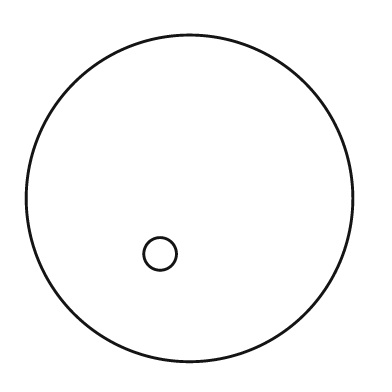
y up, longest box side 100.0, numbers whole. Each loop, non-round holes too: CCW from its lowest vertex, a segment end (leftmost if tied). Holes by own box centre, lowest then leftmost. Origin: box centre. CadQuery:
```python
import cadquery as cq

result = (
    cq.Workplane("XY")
    .moveTo(0.0, 0.0)
    .circle(50.0)
    .moveTo(-9.0, -17.0)
    .circle(5.0)
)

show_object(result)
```